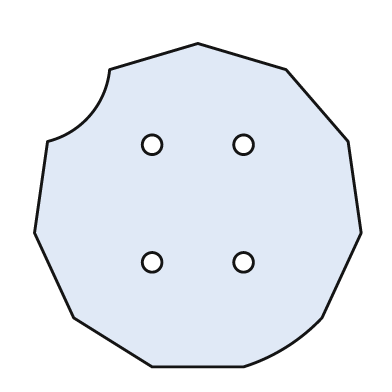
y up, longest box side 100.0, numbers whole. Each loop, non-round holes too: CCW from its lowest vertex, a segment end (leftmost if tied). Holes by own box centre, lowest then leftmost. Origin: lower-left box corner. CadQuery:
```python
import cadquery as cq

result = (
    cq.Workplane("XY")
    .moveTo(36.0, 0.0)
    .lineTo(64.0, 0.0)
    .threePointArc((77.0, 6.0), (88.0, 15.0))
    .lineTo(100.0, 41.0)
    .lineTo(96.0, 69.0)
    .lineTo(77.0, 91.0)
    .lineTo(50.0, 99.0)
    .lineTo(23.0, 91.0)
    .threePointArc((17.0, 77.0), (4.0, 69.0))
    .lineTo(0.0, 41.0)
    .lineTo(12.0, 15.0)
    .close()
    .moveTo(36.0, 32.0)
    .circle(3.0)
    .moveTo(64.0, 32.0)
    .circle(3.0)
    .moveTo(36.0, 68.0)
    .circle(3.0)
    .moveTo(64.0, 68.0)
    .circle(3.0)
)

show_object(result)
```